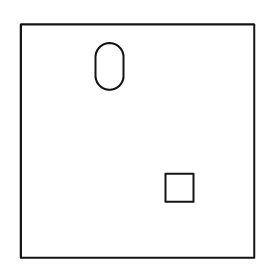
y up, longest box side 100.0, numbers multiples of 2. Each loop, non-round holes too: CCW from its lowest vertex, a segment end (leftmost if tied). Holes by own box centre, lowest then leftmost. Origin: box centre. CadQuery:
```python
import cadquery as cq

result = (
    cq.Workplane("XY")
    .moveTo(-50.0, -50.0)
    .lineTo(50.0, -50.0)
    .lineTo(50.0, 50.0)
    .lineTo(-50.0, 50.0)
    .close()
    .moveTo(12.0, -26.0)
    .lineTo(24.0, -26.0)
    .lineTo(24.0, -14.0)
    .lineTo(12.0, -14.0)
    .close()
    .moveTo(-18.0, 28.0)
    .threePointArc((-12.0, 22.0), (-6.0, 28.0))
    .lineTo(-6.0, 36.0)
    .threePointArc((-12.0, 42.0), (-18.0, 36.0))
    .close()
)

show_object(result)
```